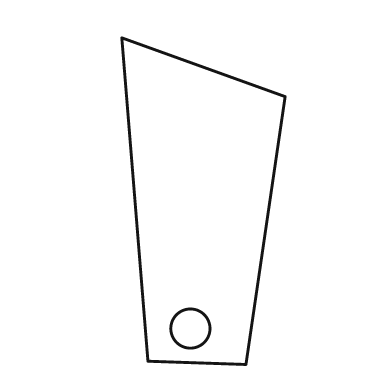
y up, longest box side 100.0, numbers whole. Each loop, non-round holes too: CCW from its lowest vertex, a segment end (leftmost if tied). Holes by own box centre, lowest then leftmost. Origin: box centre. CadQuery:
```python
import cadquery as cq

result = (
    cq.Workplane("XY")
    .moveTo(13.0, -50.0)
    .lineTo(25.0, 32.0)
    .lineTo(-25.0, 50.0)
    .lineTo(-17.0, -49.0)
    .close()
    .moveTo(-4.0, -39.0)
    .circle(6.0)
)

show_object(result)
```